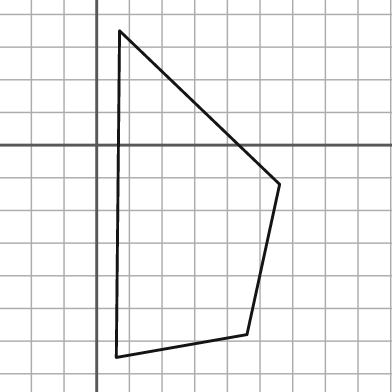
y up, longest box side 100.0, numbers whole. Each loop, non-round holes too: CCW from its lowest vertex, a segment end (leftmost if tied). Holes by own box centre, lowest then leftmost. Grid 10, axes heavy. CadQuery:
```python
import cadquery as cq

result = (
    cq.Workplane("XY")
    .moveTo(6.0, -65.0)
    .lineTo(46.0, -58.0)
    .lineTo(56.0, -12.0)
    .lineTo(7.0, 35.0)
    .close()
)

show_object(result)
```